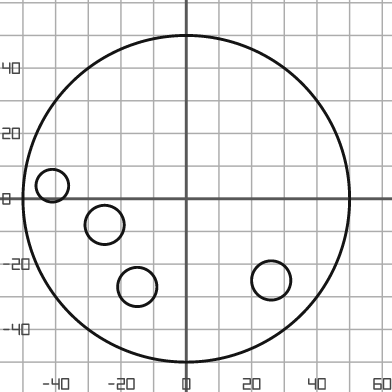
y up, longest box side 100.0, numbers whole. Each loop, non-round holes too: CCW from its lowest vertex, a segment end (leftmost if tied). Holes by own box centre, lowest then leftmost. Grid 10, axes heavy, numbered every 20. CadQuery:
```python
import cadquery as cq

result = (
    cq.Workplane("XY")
    .moveTo(0.0, 0.0)
    .circle(50.0)
    .moveTo(-15.0, -27.0)
    .circle(6.0)
    .moveTo(26.0, -25.0)
    .circle(6.0)
    .moveTo(-25.0, -8.0)
    .circle(6.0)
    .moveTo(-41.0, 4.0)
    .circle(5.0)
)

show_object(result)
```